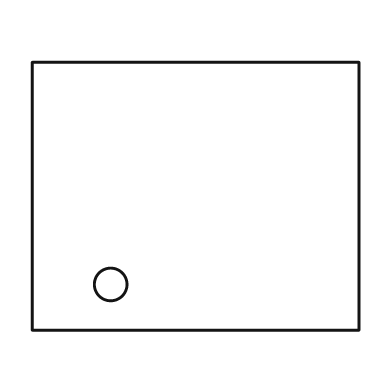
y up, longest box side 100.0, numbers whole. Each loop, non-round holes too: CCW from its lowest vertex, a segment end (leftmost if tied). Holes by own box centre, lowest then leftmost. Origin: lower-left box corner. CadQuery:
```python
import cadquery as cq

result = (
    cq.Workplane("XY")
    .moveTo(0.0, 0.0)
    .lineTo(100.0, 0.0)
    .lineTo(100.0, 82.0)
    .lineTo(0.0, 82.0)
    .close()
    .moveTo(24.0, 14.0)
    .circle(5.0)
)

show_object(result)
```